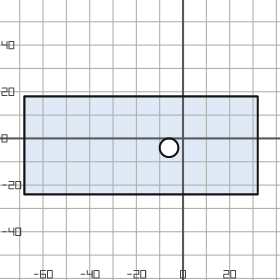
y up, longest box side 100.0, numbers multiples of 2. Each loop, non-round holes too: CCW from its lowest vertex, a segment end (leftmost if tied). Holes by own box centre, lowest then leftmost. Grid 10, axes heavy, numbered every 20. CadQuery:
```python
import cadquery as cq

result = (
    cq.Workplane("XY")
    .moveTo(-68.0, -24.0)
    .lineTo(32.0, -24.0)
    .lineTo(32.0, 18.0)
    .lineTo(-68.0, 18.0)
    .close()
    .moveTo(-6.0, -4.0)
    .circle(4.0)
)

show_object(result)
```